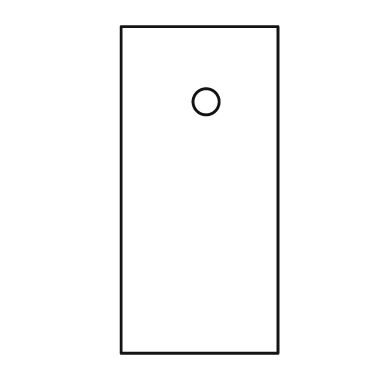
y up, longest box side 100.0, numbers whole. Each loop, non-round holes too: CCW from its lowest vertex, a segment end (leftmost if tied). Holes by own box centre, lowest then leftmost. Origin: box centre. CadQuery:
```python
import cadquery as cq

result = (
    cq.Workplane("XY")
    .moveTo(-24.0, -50.0)
    .lineTo(24.0, -50.0)
    .lineTo(24.0, 50.0)
    .lineTo(-24.0, 50.0)
    .close()
    .moveTo(2.0, 27.0)
    .circle(4.0)
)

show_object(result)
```